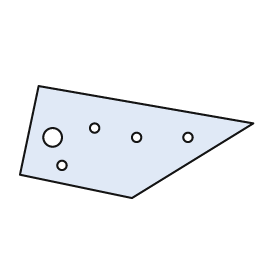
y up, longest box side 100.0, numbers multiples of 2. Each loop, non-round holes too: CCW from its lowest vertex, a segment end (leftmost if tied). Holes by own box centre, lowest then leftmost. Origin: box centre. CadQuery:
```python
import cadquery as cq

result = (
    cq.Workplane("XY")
    .moveTo(-2.0, -24.0)
    .lineTo(50.0, 8.0)
    .lineTo(-42.0, 24.0)
    .lineTo(-50.0, -14.0)
    .close()
    .moveTo(-32.0, -10.0)
    .circle(2.0)
    .moveTo(-36.0, 2.0)
    .circle(4.0)
    .moveTo(0.0, 2.0)
    .circle(2.0)
    .moveTo(22.0, 2.0)
    .circle(2.0)
    .moveTo(-18.0, 6.0)
    .circle(2.0)
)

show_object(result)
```